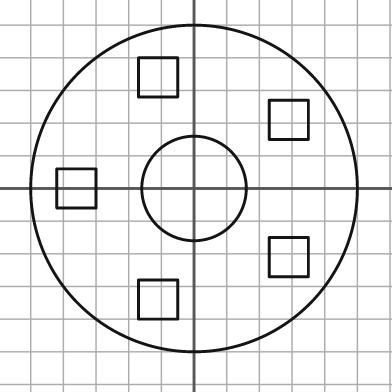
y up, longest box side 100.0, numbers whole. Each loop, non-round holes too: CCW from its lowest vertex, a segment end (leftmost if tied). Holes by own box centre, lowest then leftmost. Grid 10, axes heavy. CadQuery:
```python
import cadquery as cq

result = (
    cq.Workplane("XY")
    .moveTo(0.0, 0.0)
    .circle(50.0)
    .moveTo(-17.0, -40.0)
    .lineTo(-5.0, -40.0)
    .lineTo(-5.0, -28.0)
    .lineTo(-17.0, -28.0)
    .close()
    .moveTo(23.0, -27.0)
    .lineTo(35.0, -27.0)
    .lineTo(35.0, -15.0)
    .lineTo(23.0, -15.0)
    .close()
    .moveTo(-42.0, -6.0)
    .lineTo(-30.0, -6.0)
    .lineTo(-30.0, 6.0)
    .lineTo(-42.0, 6.0)
    .close()
    .moveTo(0.0, 0.0)
    .circle(16.0)
    .moveTo(23.0, 15.0)
    .lineTo(35.0, 15.0)
    .lineTo(35.0, 27.0)
    .lineTo(23.0, 27.0)
    .close()
    .moveTo(-17.0, 28.0)
    .lineTo(-5.0, 28.0)
    .lineTo(-5.0, 40.0)
    .lineTo(-17.0, 40.0)
    .close()
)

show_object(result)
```